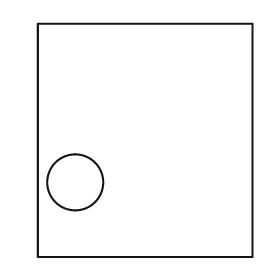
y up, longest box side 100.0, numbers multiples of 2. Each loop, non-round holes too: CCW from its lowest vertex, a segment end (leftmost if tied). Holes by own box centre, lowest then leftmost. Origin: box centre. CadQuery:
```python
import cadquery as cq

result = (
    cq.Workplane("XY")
    .moveTo(-46.0, -50.0)
    .lineTo(46.0, -50.0)
    .lineTo(46.0, 50.0)
    .lineTo(-46.0, 50.0)
    .close()
    .moveTo(-30.0, -18.0)
    .circle(12.0)
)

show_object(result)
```